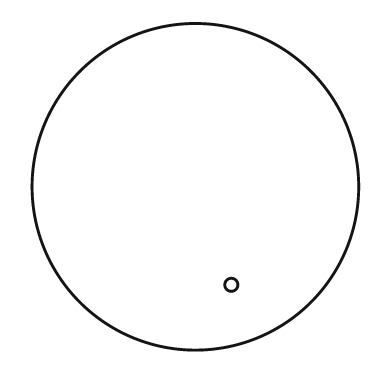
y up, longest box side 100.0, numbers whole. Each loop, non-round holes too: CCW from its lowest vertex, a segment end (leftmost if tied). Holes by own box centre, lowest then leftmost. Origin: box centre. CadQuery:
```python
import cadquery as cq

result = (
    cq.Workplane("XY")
    .moveTo(0.0, 0.0)
    .circle(50.0)
    .moveTo(11.0, -30.0)
    .circle(2.0)
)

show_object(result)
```